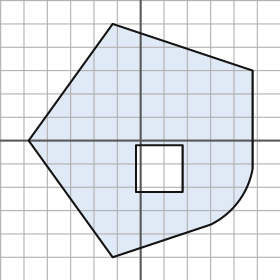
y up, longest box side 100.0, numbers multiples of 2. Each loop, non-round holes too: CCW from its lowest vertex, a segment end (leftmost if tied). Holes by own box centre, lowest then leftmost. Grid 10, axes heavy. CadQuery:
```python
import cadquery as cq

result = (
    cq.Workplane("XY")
    .moveTo(-12.0, -50.0)
    .lineTo(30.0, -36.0)
    .threePointArc((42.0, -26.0), (48.0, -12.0))
    .lineTo(48.0, 30.0)
    .lineTo(-12.0, 50.0)
    .lineTo(-48.0, 0.0)
    .close()
    .moveTo(-2.0, -22.0)
    .lineTo(18.0, -22.0)
    .lineTo(18.0, -2.0)
    .lineTo(-2.0, -2.0)
    .close()
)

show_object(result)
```